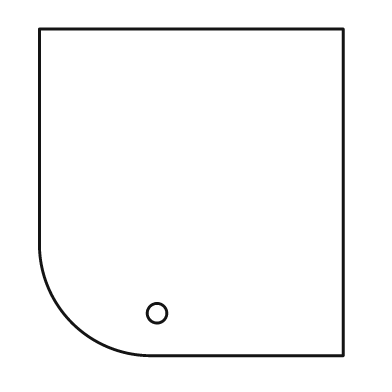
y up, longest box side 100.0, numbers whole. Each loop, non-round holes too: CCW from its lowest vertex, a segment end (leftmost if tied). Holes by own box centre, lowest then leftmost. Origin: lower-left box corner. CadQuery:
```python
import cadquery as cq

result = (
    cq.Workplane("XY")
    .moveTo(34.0, 0.0)
    .lineTo(93.0, 0.0)
    .lineTo(93.0, 100.0)
    .lineTo(0.0, 100.0)
    .lineTo(0.0, 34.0)
    .threePointArc((10.0, 10.0), (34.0, 0.0))
    .close()
    .moveTo(36.0, 13.0)
    .circle(3.0)
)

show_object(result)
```